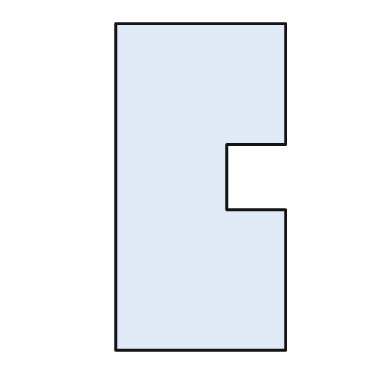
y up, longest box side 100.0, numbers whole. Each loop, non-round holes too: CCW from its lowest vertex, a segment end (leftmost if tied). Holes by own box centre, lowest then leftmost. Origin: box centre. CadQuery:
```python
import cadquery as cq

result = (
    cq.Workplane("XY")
    .moveTo(-26.0, -50.0)
    .lineTo(26.0, -50.0)
    .lineTo(26.0, -7.0)
    .lineTo(8.0, -7.0)
    .lineTo(8.0, 13.0)
    .lineTo(26.0, 13.0)
    .lineTo(26.0, 50.0)
    .lineTo(-26.0, 50.0)
    .close()
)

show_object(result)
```